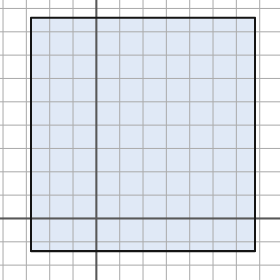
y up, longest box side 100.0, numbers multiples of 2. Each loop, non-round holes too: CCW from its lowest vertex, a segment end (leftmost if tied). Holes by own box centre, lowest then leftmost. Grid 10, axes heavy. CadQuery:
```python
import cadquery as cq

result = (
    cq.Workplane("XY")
    .moveTo(-28.0, -14.0)
    .lineTo(68.0, -14.0)
    .lineTo(68.0, 86.0)
    .lineTo(-28.0, 86.0)
    .close()
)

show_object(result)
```